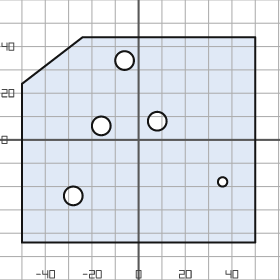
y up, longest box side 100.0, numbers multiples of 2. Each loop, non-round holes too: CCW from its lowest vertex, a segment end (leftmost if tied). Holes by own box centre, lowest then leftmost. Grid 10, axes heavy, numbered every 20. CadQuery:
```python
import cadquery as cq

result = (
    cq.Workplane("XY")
    .moveTo(-50.0, -44.0)
    .lineTo(50.0, -44.0)
    .lineTo(50.0, 44.0)
    .lineTo(-24.0, 44.0)
    .lineTo(-50.0, 24.0)
    .close()
    .moveTo(-28.0, -24.0)
    .circle(4.0)
    .moveTo(36.0, -18.0)
    .circle(2.0)
    .moveTo(-16.0, 6.0)
    .circle(4.0)
    .moveTo(8.0, 8.0)
    .circle(4.0)
    .moveTo(-6.0, 34.0)
    .circle(4.0)
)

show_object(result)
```